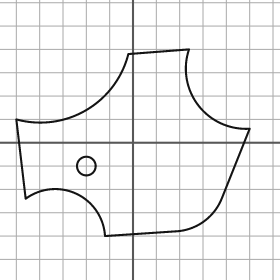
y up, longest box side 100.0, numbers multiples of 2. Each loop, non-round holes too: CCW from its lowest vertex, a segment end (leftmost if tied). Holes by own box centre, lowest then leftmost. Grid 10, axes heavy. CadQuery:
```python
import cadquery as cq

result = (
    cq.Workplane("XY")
    .moveTo(-12.0, -40.0)
    .lineTo(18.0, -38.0)
    .threePointArc((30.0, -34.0), (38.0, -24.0))
    .lineTo(50.0, 6.0)
    .threePointArc((28.0, 16.0), (24.0, 40.0))
    .lineTo(-2.0, 38.0)
    .threePointArc((-20.0, 14.0), (-50.0, 10.0))
    .lineTo(-46.0, -24.0)
    .threePointArc((-24.0, -22.0), (-12.0, -40.0))
    .close()
    .moveTo(-20.0, -10.0)
    .circle(4.0)
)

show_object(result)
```